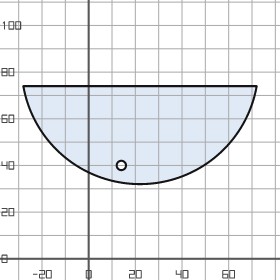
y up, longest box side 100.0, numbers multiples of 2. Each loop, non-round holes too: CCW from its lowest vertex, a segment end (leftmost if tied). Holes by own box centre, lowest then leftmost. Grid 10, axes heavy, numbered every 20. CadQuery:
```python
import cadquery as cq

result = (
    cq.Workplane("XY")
    .moveTo(-28.0, 74.0)
    .threePointArc((22.0, 32.0), (72.0, 74.0))
    .close()
    .moveTo(14.0, 40.0)
    .circle(2.0)
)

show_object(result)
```